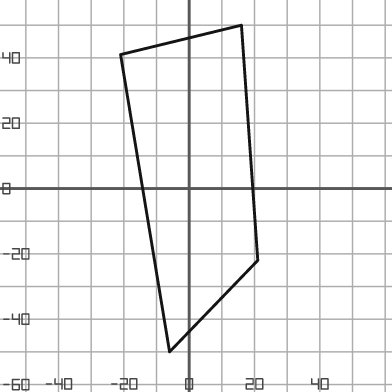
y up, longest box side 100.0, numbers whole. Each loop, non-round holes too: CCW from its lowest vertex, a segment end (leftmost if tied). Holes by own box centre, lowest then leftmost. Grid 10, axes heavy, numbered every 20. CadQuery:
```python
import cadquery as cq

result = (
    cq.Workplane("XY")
    .moveTo(-6.0, -50.0)
    .lineTo(21.0, -22.0)
    .lineTo(16.0, 50.0)
    .lineTo(-21.0, 41.0)
    .close()
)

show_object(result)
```